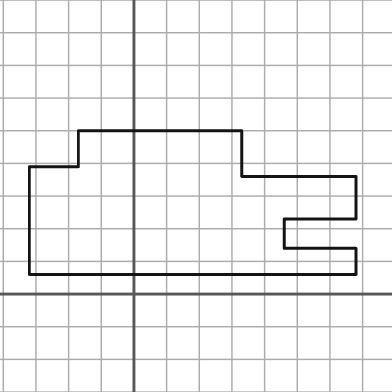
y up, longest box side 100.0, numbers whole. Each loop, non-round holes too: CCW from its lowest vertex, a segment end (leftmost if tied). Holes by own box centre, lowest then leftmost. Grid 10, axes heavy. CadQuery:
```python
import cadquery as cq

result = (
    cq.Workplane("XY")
    .moveTo(-32.0, 6.0)
    .lineTo(68.0, 6.0)
    .lineTo(68.0, 14.0)
    .lineTo(46.0, 14.0)
    .lineTo(46.0, 23.0)
    .lineTo(68.0, 23.0)
    .lineTo(68.0, 36.0)
    .lineTo(33.0, 36.0)
    .lineTo(33.0, 50.0)
    .lineTo(-17.0, 50.0)
    .lineTo(-17.0, 39.0)
    .lineTo(-32.0, 39.0)
    .close()
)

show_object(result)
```